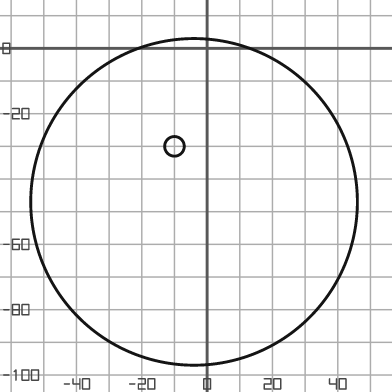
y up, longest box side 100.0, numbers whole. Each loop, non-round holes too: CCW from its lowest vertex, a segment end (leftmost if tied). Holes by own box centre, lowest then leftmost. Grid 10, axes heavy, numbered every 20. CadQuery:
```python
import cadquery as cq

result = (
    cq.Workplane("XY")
    .moveTo(-4.0, -47.0)
    .circle(50.0)
    .moveTo(-10.0, -30.0)
    .circle(3.0)
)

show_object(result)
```